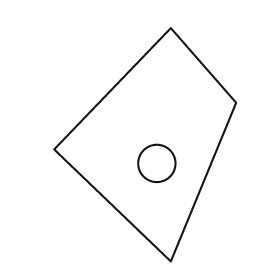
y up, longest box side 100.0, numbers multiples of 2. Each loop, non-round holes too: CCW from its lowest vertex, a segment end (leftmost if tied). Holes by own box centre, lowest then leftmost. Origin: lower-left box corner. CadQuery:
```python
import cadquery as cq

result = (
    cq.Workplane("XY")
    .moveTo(50.0, 0.0)
    .lineTo(78.0, 68.0)
    .lineTo(50.0, 100.0)
    .lineTo(0.0, 48.0)
    .close()
    .moveTo(44.0, 42.0)
    .circle(8.0)
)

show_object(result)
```